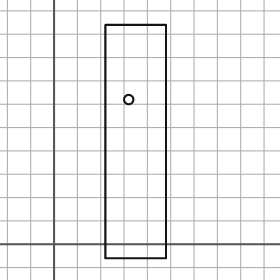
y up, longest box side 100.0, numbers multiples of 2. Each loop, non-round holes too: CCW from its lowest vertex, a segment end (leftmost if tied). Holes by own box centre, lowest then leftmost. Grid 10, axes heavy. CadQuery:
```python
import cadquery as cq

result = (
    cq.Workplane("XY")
    .moveTo(22.0, -6.0)
    .lineTo(48.0, -6.0)
    .lineTo(48.0, 94.0)
    .lineTo(22.0, 94.0)
    .close()
    .moveTo(32.0, 62.0)
    .circle(2.0)
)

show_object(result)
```